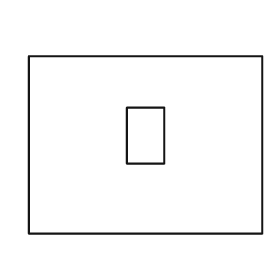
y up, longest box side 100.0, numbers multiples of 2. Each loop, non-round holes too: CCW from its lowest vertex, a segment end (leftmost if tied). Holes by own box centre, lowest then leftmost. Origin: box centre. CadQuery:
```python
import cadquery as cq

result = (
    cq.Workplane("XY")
    .moveTo(-50.0, -38.0)
    .lineTo(50.0, -38.0)
    .lineTo(50.0, 38.0)
    .lineTo(-50.0, 38.0)
    .close()
    .moveTo(-8.0, -8.0)
    .lineTo(8.0, -8.0)
    .lineTo(8.0, 16.0)
    .lineTo(-8.0, 16.0)
    .close()
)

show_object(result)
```